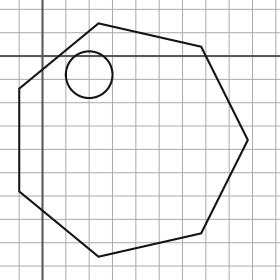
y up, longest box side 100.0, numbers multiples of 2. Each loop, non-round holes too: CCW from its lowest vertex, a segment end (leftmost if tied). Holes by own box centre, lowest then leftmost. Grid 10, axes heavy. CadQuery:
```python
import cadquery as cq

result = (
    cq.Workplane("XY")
    .moveTo(24.0, -86.0)
    .lineTo(68.0, -76.0)
    .lineTo(88.0, -36.0)
    .lineTo(68.0, 4.0)
    .lineTo(24.0, 14.0)
    .lineTo(-10.0, -14.0)
    .lineTo(-10.0, -58.0)
    .close()
    .moveTo(20.0, -8.0)
    .circle(10.0)
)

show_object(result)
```